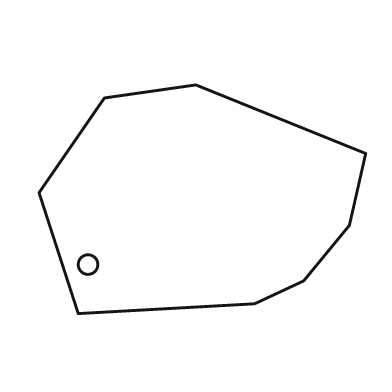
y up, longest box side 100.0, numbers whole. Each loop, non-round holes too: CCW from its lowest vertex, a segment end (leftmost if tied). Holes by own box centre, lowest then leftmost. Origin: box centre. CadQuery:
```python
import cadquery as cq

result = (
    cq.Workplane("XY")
    .moveTo(-38.0, -35.0)
    .lineTo(16.0, -32.0)
    .lineTo(31.0, -25.0)
    .lineTo(45.0, -8.0)
    .lineTo(50.0, 14.0)
    .lineTo(-2.0, 35.0)
    .lineTo(-30.0, 31.0)
    .lineTo(-50.0, 2.0)
    .close()
    .moveTo(-35.0, -20.0)
    .circle(3.0)
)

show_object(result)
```